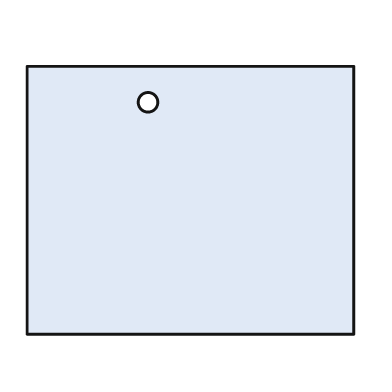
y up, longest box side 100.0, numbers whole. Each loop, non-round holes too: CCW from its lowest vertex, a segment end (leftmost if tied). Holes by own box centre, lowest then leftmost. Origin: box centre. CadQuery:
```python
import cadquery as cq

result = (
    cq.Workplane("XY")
    .moveTo(-50.0, -41.0)
    .lineTo(50.0, -41.0)
    .lineTo(50.0, 41.0)
    .lineTo(-50.0, 41.0)
    .close()
    .moveTo(-13.0, 30.0)
    .circle(3.0)
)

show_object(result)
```